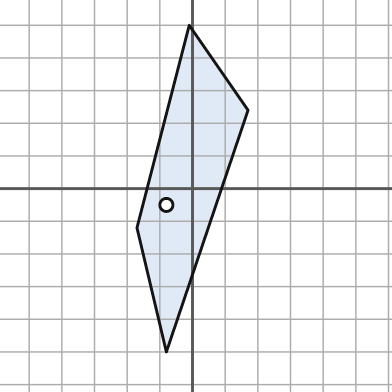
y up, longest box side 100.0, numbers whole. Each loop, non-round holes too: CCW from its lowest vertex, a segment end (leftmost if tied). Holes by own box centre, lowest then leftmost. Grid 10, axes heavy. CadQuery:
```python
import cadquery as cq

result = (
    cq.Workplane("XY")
    .moveTo(-8.0, -50.0)
    .lineTo(17.0, 24.0)
    .lineTo(-1.0, 50.0)
    .lineTo(-17.0, -12.0)
    .close()
    .moveTo(-8.0, -5.0)
    .circle(2.0)
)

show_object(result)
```